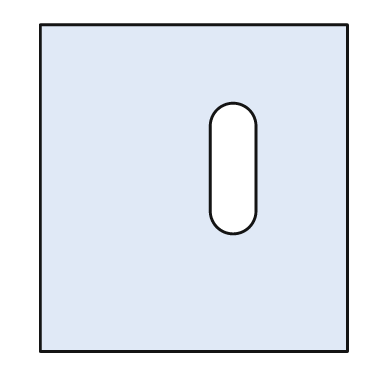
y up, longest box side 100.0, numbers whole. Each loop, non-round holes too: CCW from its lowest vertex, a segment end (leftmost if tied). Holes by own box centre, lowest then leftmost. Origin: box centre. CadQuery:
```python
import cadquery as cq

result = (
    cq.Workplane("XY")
    .moveTo(-47.0, -50.0)
    .lineTo(47.0, -50.0)
    .lineTo(47.0, 50.0)
    .lineTo(-47.0, 50.0)
    .close()
    .moveTo(5.0, -7.0)
    .threePointArc((12.0, -14.0), (19.0, -7.0))
    .lineTo(19.0, 19.0)
    .threePointArc((12.0, 26.0), (5.0, 19.0))
    .close()
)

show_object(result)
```